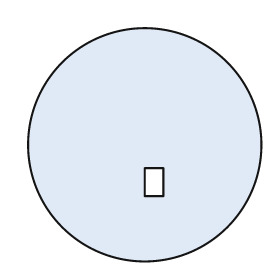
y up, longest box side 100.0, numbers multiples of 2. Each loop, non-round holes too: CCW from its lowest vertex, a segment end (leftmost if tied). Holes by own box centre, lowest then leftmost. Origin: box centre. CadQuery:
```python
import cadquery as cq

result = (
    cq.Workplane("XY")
    .moveTo(0.0, 0.0)
    .circle(50.0)
    .moveTo(0.0, -22.0)
    .lineTo(8.0, -22.0)
    .lineTo(8.0, -10.0)
    .lineTo(0.0, -10.0)
    .close()
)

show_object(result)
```